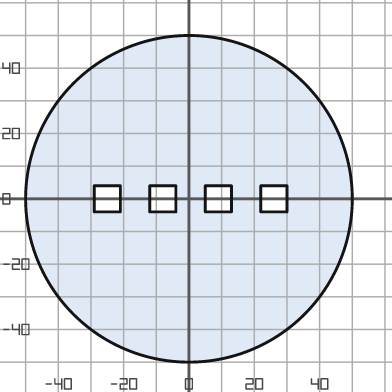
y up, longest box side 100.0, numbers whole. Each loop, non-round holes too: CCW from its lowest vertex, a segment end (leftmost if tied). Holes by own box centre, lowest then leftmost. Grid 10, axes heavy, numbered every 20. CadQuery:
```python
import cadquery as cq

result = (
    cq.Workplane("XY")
    .moveTo(0.0, 0.0)
    .circle(50.0)
    .moveTo(-29.0, -4.0)
    .lineTo(-21.0, -4.0)
    .lineTo(-21.0, 4.0)
    .lineTo(-29.0, 4.0)
    .close()
    .moveTo(-12.0, -4.0)
    .lineTo(-4.0, -4.0)
    .lineTo(-4.0, 4.0)
    .lineTo(-12.0, 4.0)
    .close()
    .moveTo(5.0, -4.0)
    .lineTo(13.0, -4.0)
    .lineTo(13.0, 4.0)
    .lineTo(5.0, 4.0)
    .close()
    .moveTo(22.0, -4.0)
    .lineTo(30.0, -4.0)
    .lineTo(30.0, 4.0)
    .lineTo(22.0, 4.0)
    .close()
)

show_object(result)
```